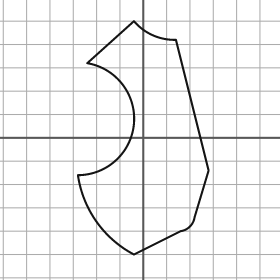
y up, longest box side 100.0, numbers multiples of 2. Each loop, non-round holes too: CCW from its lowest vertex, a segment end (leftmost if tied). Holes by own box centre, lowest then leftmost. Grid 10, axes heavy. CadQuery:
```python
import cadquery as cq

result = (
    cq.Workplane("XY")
    .moveTo(-4.0, -50.0)
    .lineTo(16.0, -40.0)
    .threePointArc((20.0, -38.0), (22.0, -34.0))
    .lineTo(28.0, -14.0)
    .lineTo(14.0, 42.0)
    .threePointArc((4.0, 44.0), (-4.0, 50.0))
    .lineTo(-24.0, 32.0)
    .threePointArc((-4.0, 6.0), (-28.0, -16.0))
    .threePointArc((-20.0, -36.0), (-4.0, -50.0))
    .close()
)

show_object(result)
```